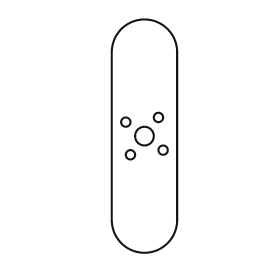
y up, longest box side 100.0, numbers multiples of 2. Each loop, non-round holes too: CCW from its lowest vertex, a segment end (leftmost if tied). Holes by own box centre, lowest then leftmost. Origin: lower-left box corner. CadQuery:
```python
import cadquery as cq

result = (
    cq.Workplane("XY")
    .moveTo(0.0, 14.0)
    .threePointArc((14.0, 0.0), (28.0, 14.0))
    .lineTo(28.0, 86.0)
    .threePointArc((14.0, 100.0), (0.0, 86.0))
    .close()
    .moveTo(8.0, 42.0)
    .circle(2.0)
    .moveTo(22.0, 44.0)
    .circle(2.0)
    .moveTo(14.0, 50.0)
    .circle(4.0)
    .moveTo(6.0, 56.0)
    .circle(2.0)
    .moveTo(20.0, 58.0)
    .circle(2.0)
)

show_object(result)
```